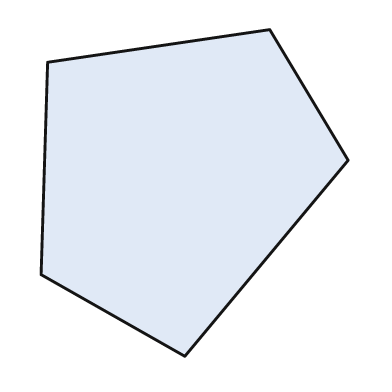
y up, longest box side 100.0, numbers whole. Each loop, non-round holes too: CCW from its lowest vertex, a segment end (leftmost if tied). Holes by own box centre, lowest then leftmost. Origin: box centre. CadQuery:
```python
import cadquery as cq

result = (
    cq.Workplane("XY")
    .moveTo(-3.0, -50.0)
    .lineTo(47.0, 10.0)
    .lineTo(23.0, 50.0)
    .lineTo(-45.0, 40.0)
    .lineTo(-47.0, -25.0)
    .close()
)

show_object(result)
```